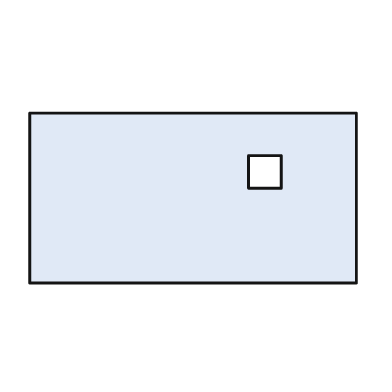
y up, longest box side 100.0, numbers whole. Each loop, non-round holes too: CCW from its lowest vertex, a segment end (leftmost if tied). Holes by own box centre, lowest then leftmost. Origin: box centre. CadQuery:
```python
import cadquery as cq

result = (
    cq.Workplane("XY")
    .moveTo(-50.0, -26.0)
    .lineTo(50.0, -26.0)
    .lineTo(50.0, 26.0)
    .lineTo(-50.0, 26.0)
    .close()
    .moveTo(17.0, 3.0)
    .lineTo(27.0, 3.0)
    .lineTo(27.0, 13.0)
    .lineTo(17.0, 13.0)
    .close()
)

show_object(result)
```